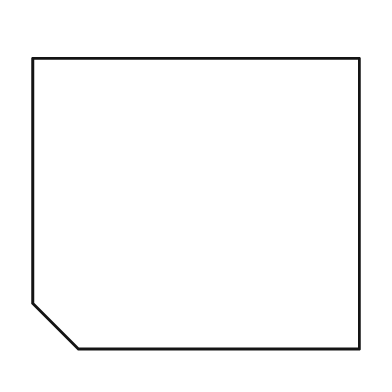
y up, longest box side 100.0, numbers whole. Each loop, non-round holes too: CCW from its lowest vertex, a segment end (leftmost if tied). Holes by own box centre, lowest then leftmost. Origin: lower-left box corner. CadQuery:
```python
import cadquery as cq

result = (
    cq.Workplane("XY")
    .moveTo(14.0, 0.0)
    .lineTo(100.0, 0.0)
    .lineTo(100.0, 89.0)
    .lineTo(0.0, 89.0)
    .lineTo(0.0, 14.0)
    .close()
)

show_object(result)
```